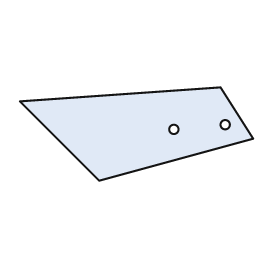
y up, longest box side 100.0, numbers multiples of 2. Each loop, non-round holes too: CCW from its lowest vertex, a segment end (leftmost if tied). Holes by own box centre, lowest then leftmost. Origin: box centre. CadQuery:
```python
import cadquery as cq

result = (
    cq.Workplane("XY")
    .moveTo(-16.0, -20.0)
    .lineTo(50.0, -2.0)
    .lineTo(36.0, 20.0)
    .lineTo(-50.0, 14.0)
    .close()
    .moveTo(16.0, 2.0)
    .circle(2.0)
    .moveTo(38.0, 4.0)
    .circle(2.0)
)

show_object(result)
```